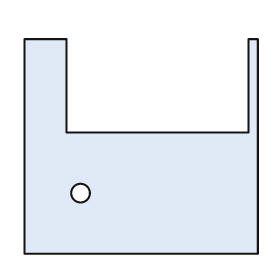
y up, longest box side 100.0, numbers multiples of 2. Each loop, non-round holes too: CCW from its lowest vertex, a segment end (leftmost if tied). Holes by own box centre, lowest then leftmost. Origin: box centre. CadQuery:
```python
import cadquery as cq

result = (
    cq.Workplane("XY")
    .moveTo(-50.0, -46.0)
    .lineTo(50.0, -46.0)
    .lineTo(50.0, 46.0)
    .lineTo(46.0, 46.0)
    .lineTo(46.0, 6.0)
    .lineTo(-32.0, 6.0)
    .lineTo(-32.0, 46.0)
    .lineTo(-50.0, 46.0)
    .close()
    .moveTo(-26.0, -20.0)
    .circle(4.0)
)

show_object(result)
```